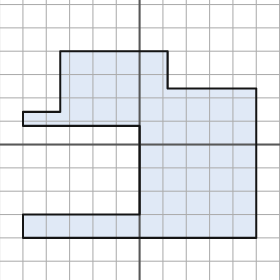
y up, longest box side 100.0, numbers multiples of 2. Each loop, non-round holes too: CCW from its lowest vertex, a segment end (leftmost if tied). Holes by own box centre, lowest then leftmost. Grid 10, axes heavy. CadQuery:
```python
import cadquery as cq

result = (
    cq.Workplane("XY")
    .moveTo(-50.0, -40.0)
    .lineTo(50.0, -40.0)
    .lineTo(50.0, 24.0)
    .lineTo(12.0, 24.0)
    .lineTo(12.0, 40.0)
    .lineTo(-34.0, 40.0)
    .lineTo(-34.0, 14.0)
    .lineTo(-50.0, 14.0)
    .lineTo(-50.0, 8.0)
    .lineTo(0.0, 8.0)
    .lineTo(0.0, -30.0)
    .lineTo(-50.0, -30.0)
    .close()
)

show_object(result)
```